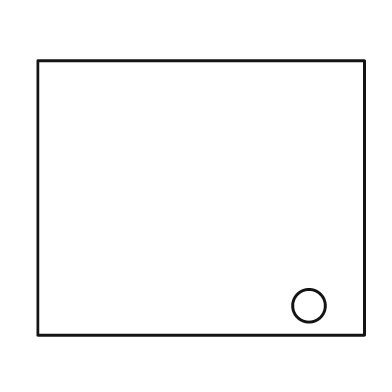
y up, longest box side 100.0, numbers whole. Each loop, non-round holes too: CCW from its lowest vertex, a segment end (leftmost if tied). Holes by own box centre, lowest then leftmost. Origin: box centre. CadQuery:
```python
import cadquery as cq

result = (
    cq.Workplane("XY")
    .moveTo(-50.0, -42.0)
    .lineTo(50.0, -42.0)
    .lineTo(50.0, 42.0)
    .lineTo(-50.0, 42.0)
    .close()
    .moveTo(33.0, -33.0)
    .circle(5.0)
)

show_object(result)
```